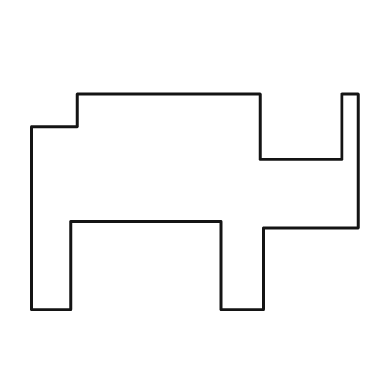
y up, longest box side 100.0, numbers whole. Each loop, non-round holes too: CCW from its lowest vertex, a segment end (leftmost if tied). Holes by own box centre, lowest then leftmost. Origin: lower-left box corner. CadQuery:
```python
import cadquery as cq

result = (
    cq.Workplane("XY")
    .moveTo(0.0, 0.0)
    .lineTo(12.0, 0.0)
    .lineTo(12.0, 27.0)
    .lineTo(58.0, 27.0)
    .lineTo(58.0, 0.0)
    .lineTo(71.0, 0.0)
    .lineTo(71.0, 25.0)
    .lineTo(100.0, 25.0)
    .lineTo(100.0, 66.0)
    .lineTo(95.0, 66.0)
    .lineTo(95.0, 46.0)
    .lineTo(70.0, 46.0)
    .lineTo(70.0, 66.0)
    .lineTo(14.0, 66.0)
    .lineTo(14.0, 56.0)
    .lineTo(0.0, 56.0)
    .close()
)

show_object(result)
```